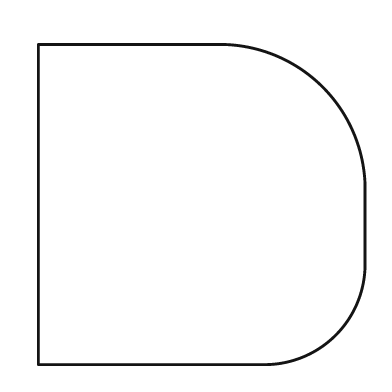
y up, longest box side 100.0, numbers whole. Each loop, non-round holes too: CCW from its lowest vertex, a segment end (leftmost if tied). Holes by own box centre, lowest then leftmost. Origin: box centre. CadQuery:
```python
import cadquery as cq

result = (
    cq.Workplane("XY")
    .moveTo(-50.0, -49.0)
    .lineTo(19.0, -49.0)
    .threePointArc((41.0, -40.0), (50.0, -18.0))
    .lineTo(50.0, 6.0)
    .threePointArc((37.0, 36.0), (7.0, 49.0))
    .lineTo(-50.0, 49.0)
    .close()
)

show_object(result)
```